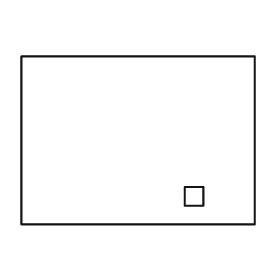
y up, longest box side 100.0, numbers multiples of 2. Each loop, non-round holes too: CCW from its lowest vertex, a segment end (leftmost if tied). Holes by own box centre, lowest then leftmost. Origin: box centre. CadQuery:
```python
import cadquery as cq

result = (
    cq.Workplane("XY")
    .moveTo(-50.0, -36.0)
    .lineTo(50.0, -36.0)
    .lineTo(50.0, 36.0)
    .lineTo(-50.0, 36.0)
    .close()
    .moveTo(20.0, -28.0)
    .lineTo(28.0, -28.0)
    .lineTo(28.0, -20.0)
    .lineTo(20.0, -20.0)
    .close()
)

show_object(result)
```